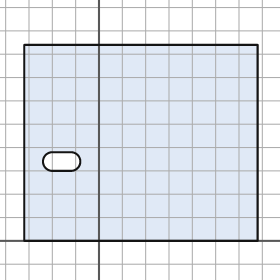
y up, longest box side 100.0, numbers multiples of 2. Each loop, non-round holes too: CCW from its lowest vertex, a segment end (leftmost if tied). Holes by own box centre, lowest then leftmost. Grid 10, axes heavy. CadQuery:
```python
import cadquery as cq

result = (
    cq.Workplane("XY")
    .moveTo(-32.0, 0.0)
    .lineTo(68.0, 0.0)
    .lineTo(68.0, 84.0)
    .lineTo(-32.0, 84.0)
    .close()
    .moveTo(-20.0, 30.0)
    .lineTo(-12.0, 30.0)
    .threePointArc((-8.0, 34.0), (-12.0, 38.0))
    .lineTo(-20.0, 38.0)
    .threePointArc((-24.0, 34.0), (-20.0, 30.0))
    .close()
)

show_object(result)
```